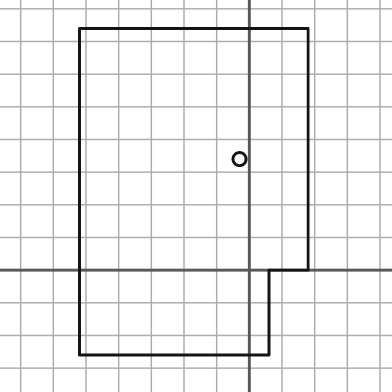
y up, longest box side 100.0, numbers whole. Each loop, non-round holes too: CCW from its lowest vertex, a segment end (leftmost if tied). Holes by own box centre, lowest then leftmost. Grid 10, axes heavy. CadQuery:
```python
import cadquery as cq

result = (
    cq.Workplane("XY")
    .moveTo(-52.0, -26.0)
    .lineTo(6.0, -26.0)
    .lineTo(6.0, 0.0)
    .lineTo(18.0, 0.0)
    .lineTo(18.0, 74.0)
    .lineTo(-52.0, 74.0)
    .close()
    .moveTo(-3.0, 34.0)
    .circle(2.0)
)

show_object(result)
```